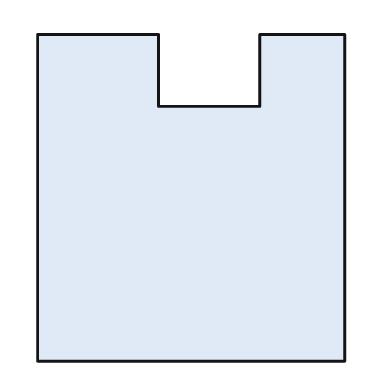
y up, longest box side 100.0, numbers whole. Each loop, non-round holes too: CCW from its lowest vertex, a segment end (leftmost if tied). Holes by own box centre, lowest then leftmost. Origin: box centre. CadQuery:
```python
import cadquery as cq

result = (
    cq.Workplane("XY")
    .moveTo(-47.0, -50.0)
    .lineTo(47.0, -50.0)
    .lineTo(47.0, 50.0)
    .lineTo(21.0, 50.0)
    .lineTo(21.0, 28.0)
    .lineTo(-10.0, 28.0)
    .lineTo(-10.0, 50.0)
    .lineTo(-47.0, 50.0)
    .close()
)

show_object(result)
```